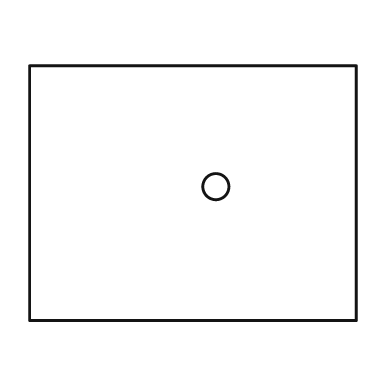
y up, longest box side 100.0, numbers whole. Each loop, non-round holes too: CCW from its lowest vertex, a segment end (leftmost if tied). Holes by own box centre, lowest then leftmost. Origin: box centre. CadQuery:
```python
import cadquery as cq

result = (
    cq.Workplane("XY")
    .moveTo(-50.0, -39.0)
    .lineTo(50.0, -39.0)
    .lineTo(50.0, 39.0)
    .lineTo(-50.0, 39.0)
    .close()
    .moveTo(7.0, 2.0)
    .circle(4.0)
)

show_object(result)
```